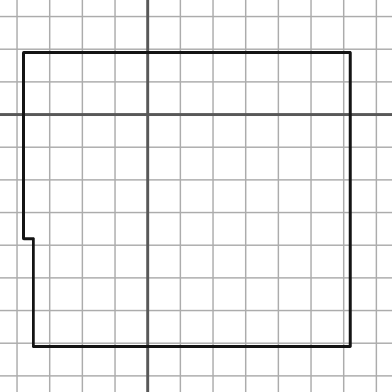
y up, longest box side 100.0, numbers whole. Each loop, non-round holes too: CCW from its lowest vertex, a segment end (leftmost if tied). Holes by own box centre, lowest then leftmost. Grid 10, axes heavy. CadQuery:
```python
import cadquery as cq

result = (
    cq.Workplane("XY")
    .moveTo(-35.0, -71.0)
    .lineTo(62.0, -71.0)
    .lineTo(62.0, 19.0)
    .lineTo(-38.0, 19.0)
    .lineTo(-38.0, -38.0)
    .lineTo(-35.0, -38.0)
    .close()
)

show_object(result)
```